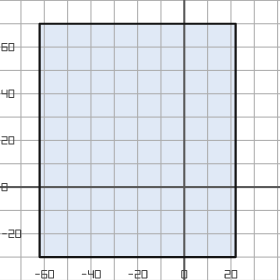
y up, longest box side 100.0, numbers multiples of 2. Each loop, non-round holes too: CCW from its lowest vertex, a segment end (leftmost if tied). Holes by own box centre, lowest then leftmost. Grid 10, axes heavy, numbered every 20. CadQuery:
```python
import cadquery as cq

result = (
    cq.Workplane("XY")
    .moveTo(-62.0, -30.0)
    .lineTo(22.0, -30.0)
    .lineTo(22.0, 70.0)
    .lineTo(-62.0, 70.0)
    .close()
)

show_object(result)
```